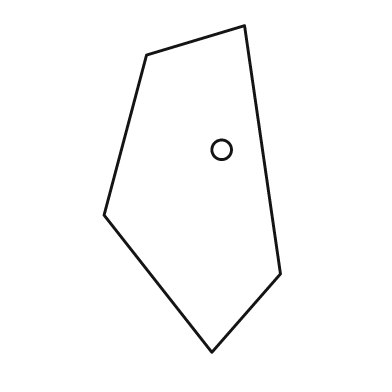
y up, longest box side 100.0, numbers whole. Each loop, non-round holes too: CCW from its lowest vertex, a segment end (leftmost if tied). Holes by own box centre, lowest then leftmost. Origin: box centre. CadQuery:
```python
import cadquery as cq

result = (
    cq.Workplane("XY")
    .moveTo(6.0, -50.0)
    .lineTo(27.0, -26.0)
    .lineTo(16.0, 50.0)
    .lineTo(-14.0, 41.0)
    .lineTo(-27.0, -8.0)
    .close()
    .moveTo(9.0, 12.0)
    .circle(3.0)
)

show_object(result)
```